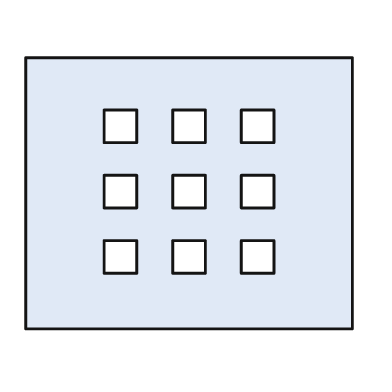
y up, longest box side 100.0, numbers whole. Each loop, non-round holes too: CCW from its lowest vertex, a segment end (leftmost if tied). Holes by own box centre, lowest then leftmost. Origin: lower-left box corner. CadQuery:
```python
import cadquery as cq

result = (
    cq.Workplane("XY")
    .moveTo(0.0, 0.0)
    .lineTo(100.0, 0.0)
    .lineTo(100.0, 83.0)
    .lineTo(0.0, 83.0)
    .close()
    .moveTo(24.0, 17.0)
    .lineTo(34.0, 17.0)
    .lineTo(34.0, 27.0)
    .lineTo(24.0, 27.0)
    .close()
    .moveTo(45.0, 17.0)
    .lineTo(55.0, 17.0)
    .lineTo(55.0, 27.0)
    .lineTo(45.0, 27.0)
    .close()
    .moveTo(66.0, 17.0)
    .lineTo(76.0, 17.0)
    .lineTo(76.0, 27.0)
    .lineTo(66.0, 27.0)
    .close()
    .moveTo(24.0, 37.0)
    .lineTo(34.0, 37.0)
    .lineTo(34.0, 47.0)
    .lineTo(24.0, 47.0)
    .close()
    .moveTo(45.0, 37.0)
    .lineTo(55.0, 37.0)
    .lineTo(55.0, 47.0)
    .lineTo(45.0, 47.0)
    .close()
    .moveTo(66.0, 37.0)
    .lineTo(76.0, 37.0)
    .lineTo(76.0, 47.0)
    .lineTo(66.0, 47.0)
    .close()
    .moveTo(24.0, 57.0)
    .lineTo(34.0, 57.0)
    .lineTo(34.0, 67.0)
    .lineTo(24.0, 67.0)
    .close()
    .moveTo(45.0, 57.0)
    .lineTo(55.0, 57.0)
    .lineTo(55.0, 67.0)
    .lineTo(45.0, 67.0)
    .close()
    .moveTo(66.0, 57.0)
    .lineTo(76.0, 57.0)
    .lineTo(76.0, 67.0)
    .lineTo(66.0, 67.0)
    .close()
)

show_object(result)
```